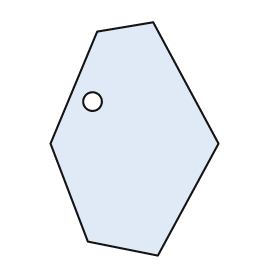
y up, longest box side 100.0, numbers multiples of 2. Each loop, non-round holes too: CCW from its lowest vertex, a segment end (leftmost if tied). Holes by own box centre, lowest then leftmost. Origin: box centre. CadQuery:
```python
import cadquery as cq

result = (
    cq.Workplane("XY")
    .moveTo(10.0, -50.0)
    .lineTo(36.0, -2.0)
    .lineTo(8.0, 50.0)
    .lineTo(-16.0, 46.0)
    .lineTo(-36.0, -2.0)
    .lineTo(-20.0, -44.0)
    .close()
    .moveTo(-18.0, 16.0)
    .circle(4.0)
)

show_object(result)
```